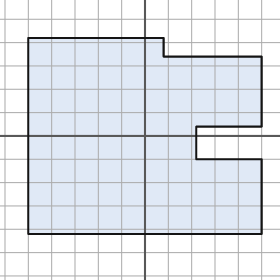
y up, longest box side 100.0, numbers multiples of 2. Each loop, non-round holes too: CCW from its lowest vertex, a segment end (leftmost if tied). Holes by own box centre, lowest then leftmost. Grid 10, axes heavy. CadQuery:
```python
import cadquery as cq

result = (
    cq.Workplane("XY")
    .moveTo(-50.0, -42.0)
    .lineTo(50.0, -42.0)
    .lineTo(50.0, -10.0)
    .lineTo(22.0, -10.0)
    .lineTo(22.0, 4.0)
    .lineTo(50.0, 4.0)
    .lineTo(50.0, 34.0)
    .lineTo(8.0, 34.0)
    .lineTo(8.0, 42.0)
    .lineTo(-50.0, 42.0)
    .close()
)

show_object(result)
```